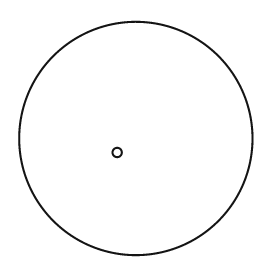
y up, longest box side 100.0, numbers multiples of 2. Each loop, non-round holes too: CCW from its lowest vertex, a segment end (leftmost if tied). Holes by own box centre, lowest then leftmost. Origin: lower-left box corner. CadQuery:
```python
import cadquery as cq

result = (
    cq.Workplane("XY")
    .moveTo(50.0, 50.0)
    .circle(50.0)
    .moveTo(42.0, 44.0)
    .circle(2.0)
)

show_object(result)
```